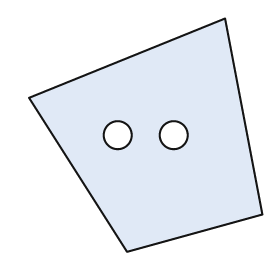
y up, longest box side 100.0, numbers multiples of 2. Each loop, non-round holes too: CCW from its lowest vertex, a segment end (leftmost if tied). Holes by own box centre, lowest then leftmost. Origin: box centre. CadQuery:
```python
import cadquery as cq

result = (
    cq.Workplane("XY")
    .moveTo(-8.0, -50.0)
    .lineTo(50.0, -34.0)
    .lineTo(34.0, 50.0)
    .lineTo(-50.0, 16.0)
    .close()
    .moveTo(-12.0, 0.0)
    .circle(6.0)
    .moveTo(12.0, 0.0)
    .circle(6.0)
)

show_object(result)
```